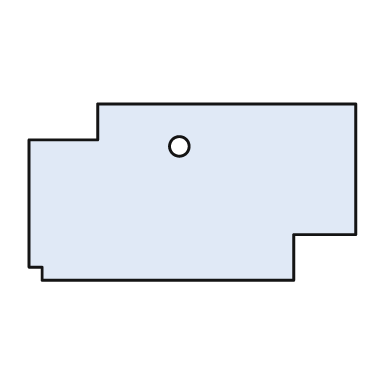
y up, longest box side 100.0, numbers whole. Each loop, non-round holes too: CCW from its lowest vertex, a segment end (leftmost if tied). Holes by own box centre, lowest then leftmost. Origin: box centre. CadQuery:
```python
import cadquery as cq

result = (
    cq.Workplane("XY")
    .moveTo(-46.0, -27.0)
    .lineTo(31.0, -27.0)
    .lineTo(31.0, -13.0)
    .lineTo(50.0, -13.0)
    .lineTo(50.0, 27.0)
    .lineTo(-29.0, 27.0)
    .lineTo(-29.0, 16.0)
    .lineTo(-50.0, 16.0)
    .lineTo(-50.0, -23.0)
    .lineTo(-46.0, -23.0)
    .close()
    .moveTo(-4.0, 14.0)
    .circle(3.0)
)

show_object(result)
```